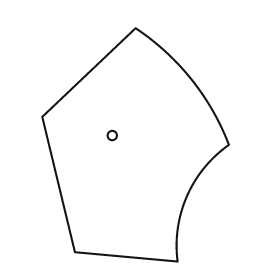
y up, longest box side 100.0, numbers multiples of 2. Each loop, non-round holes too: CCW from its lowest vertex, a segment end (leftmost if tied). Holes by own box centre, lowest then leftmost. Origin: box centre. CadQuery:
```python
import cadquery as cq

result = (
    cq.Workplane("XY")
    .moveTo(18.0, -50.0)
    .threePointArc((22.0, -22.0), (40.0, 0.0))
    .threePointArc((24.0, 28.0), (0.0, 50.0))
    .lineTo(-40.0, 12.0)
    .lineTo(-26.0, -46.0)
    .close()
    .moveTo(-10.0, 4.0)
    .circle(2.0)
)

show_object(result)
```